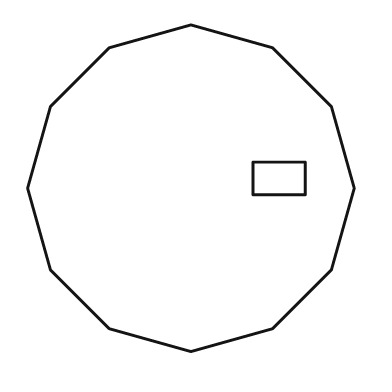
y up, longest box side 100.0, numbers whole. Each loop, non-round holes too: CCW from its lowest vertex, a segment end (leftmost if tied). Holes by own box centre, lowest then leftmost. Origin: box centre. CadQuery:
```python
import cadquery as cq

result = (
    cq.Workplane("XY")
    .moveTo(0.0, -50.0)
    .lineTo(25.0, -43.0)
    .lineTo(43.0, -25.0)
    .lineTo(50.0, 0.0)
    .lineTo(43.0, 25.0)
    .lineTo(25.0, 43.0)
    .lineTo(0.0, 50.0)
    .lineTo(-25.0, 43.0)
    .lineTo(-43.0, 25.0)
    .lineTo(-50.0, 0.0)
    .lineTo(-43.0, -25.0)
    .lineTo(-25.0, -43.0)
    .close()
    .moveTo(19.0, -2.0)
    .lineTo(35.0, -2.0)
    .lineTo(35.0, 8.0)
    .lineTo(19.0, 8.0)
    .close()
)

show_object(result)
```